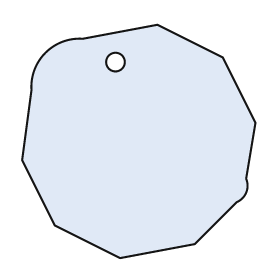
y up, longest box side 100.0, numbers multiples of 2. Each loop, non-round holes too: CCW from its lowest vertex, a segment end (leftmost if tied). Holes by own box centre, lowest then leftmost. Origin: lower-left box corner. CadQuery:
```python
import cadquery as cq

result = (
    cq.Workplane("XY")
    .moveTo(42.0, 0.0)
    .lineTo(74.0, 6.0)
    .lineTo(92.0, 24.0)
    .threePointArc((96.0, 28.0), (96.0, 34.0))
    .lineTo(100.0, 58.0)
    .lineTo(86.0, 86.0)
    .lineTo(58.0, 100.0)
    .lineTo(26.0, 94.0)
    .threePointArc((10.0, 88.0), (4.0, 72.0))
    .lineTo(0.0, 42.0)
    .lineTo(14.0, 14.0)
    .close()
    .moveTo(40.0, 84.0)
    .circle(4.0)
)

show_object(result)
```